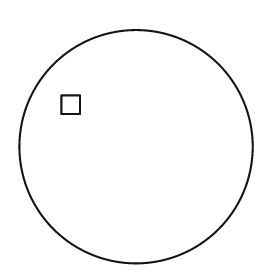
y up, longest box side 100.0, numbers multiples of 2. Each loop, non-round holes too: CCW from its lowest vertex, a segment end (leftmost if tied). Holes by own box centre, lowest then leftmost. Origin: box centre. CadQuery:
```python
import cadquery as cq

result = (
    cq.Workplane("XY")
    .moveTo(0.0, 0.0)
    .circle(50.0)
    .moveTo(-32.0, 14.0)
    .lineTo(-24.0, 14.0)
    .lineTo(-24.0, 22.0)
    .lineTo(-32.0, 22.0)
    .close()
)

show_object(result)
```